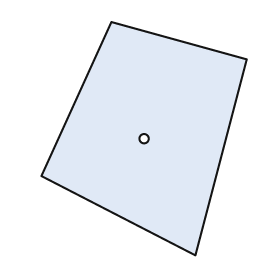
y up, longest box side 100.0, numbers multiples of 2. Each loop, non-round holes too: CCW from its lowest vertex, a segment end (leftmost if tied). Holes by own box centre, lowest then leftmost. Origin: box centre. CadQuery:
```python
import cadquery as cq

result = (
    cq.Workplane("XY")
    .moveTo(22.0, -50.0)
    .lineTo(44.0, 34.0)
    .lineTo(-14.0, 50.0)
    .lineTo(-44.0, -16.0)
    .close()
    .moveTo(0.0, 0.0)
    .circle(2.0)
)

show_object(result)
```